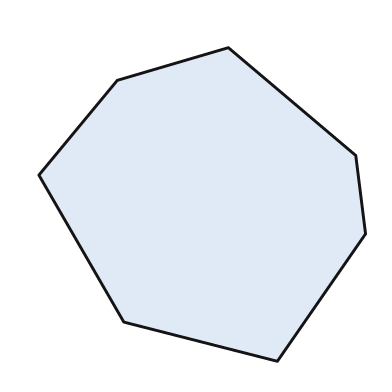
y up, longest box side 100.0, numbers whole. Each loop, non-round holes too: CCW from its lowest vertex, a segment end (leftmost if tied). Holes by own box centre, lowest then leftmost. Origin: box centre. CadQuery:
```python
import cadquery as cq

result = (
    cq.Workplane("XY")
    .moveTo(23.0, -48.0)
    .lineTo(50.0, -9.0)
    .lineTo(47.0, 15.0)
    .lineTo(8.0, 48.0)
    .lineTo(-26.0, 38.0)
    .lineTo(-50.0, 9.0)
    .lineTo(-24.0, -36.0)
    .close()
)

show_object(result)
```